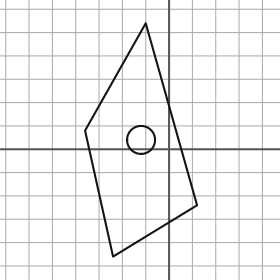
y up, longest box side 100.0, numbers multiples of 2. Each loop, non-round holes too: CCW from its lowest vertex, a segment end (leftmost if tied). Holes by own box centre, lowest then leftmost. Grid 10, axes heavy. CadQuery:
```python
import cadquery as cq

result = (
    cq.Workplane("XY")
    .moveTo(-24.0, -46.0)
    .lineTo(12.0, -24.0)
    .lineTo(-10.0, 54.0)
    .lineTo(-36.0, 8.0)
    .close()
    .moveTo(-12.0, 4.0)
    .circle(6.0)
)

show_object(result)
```